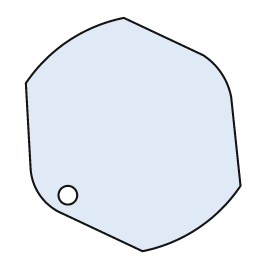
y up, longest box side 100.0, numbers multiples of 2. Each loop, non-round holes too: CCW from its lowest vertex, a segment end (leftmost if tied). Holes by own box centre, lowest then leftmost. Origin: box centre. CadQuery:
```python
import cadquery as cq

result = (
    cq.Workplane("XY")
    .moveTo(4.0, -50.0)
    .threePointArc((28.0, -40.0), (46.0, -22.0))
    .lineTo(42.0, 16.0)
    .threePointArc((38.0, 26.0), (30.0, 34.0))
    .lineTo(-4.0, 50.0)
    .threePointArc((-28.0, 40.0), (-46.0, 22.0))
    .lineTo(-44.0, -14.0)
    .threePointArc((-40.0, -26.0), (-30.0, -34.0))
    .close()
    .moveTo(-28.0, -26.0)
    .circle(4.0)
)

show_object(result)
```